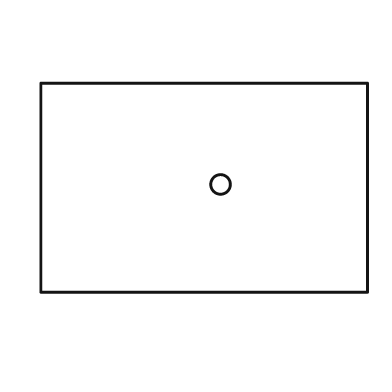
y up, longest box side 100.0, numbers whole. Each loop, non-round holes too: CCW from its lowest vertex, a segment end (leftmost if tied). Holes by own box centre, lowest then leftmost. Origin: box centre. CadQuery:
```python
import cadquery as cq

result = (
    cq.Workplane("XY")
    .moveTo(-50.0, -32.0)
    .lineTo(50.0, -32.0)
    .lineTo(50.0, 32.0)
    .lineTo(-50.0, 32.0)
    .close()
    .moveTo(5.0, 1.0)
    .circle(3.0)
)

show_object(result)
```